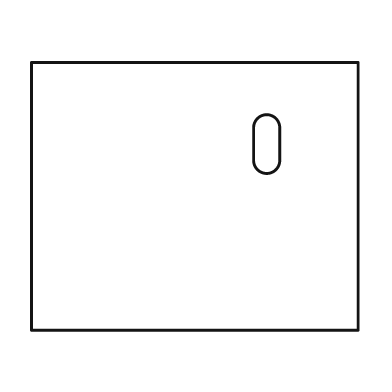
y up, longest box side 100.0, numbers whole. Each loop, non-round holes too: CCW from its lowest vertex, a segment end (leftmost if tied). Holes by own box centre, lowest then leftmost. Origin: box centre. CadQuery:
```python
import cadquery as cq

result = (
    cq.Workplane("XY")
    .moveTo(-50.0, -41.0)
    .lineTo(50.0, -41.0)
    .lineTo(50.0, 41.0)
    .lineTo(-50.0, 41.0)
    .close()
    .moveTo(18.0, 11.0)
    .threePointArc((22.0, 7.0), (26.0, 11.0))
    .lineTo(26.0, 21.0)
    .threePointArc((22.0, 25.0), (18.0, 21.0))
    .close()
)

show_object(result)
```